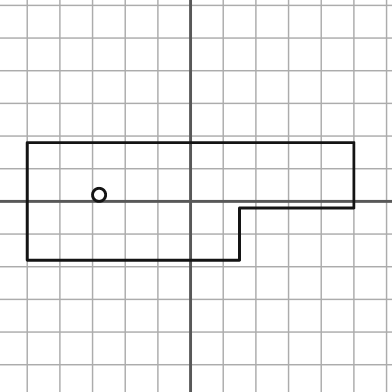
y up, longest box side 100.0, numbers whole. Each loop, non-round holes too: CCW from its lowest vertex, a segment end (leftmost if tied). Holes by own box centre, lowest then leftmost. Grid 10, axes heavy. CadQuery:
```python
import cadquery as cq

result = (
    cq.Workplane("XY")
    .moveTo(-50.0, -18.0)
    .lineTo(15.0, -18.0)
    .lineTo(15.0, -2.0)
    .lineTo(50.0, -2.0)
    .lineTo(50.0, 18.0)
    .lineTo(-50.0, 18.0)
    .close()
    .moveTo(-28.0, 2.0)
    .circle(2.0)
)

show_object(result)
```